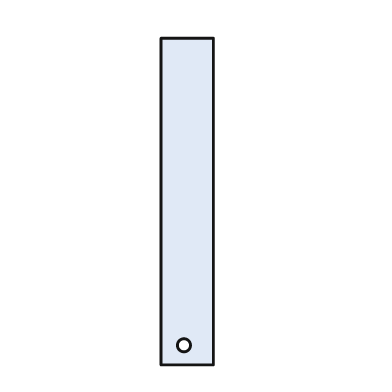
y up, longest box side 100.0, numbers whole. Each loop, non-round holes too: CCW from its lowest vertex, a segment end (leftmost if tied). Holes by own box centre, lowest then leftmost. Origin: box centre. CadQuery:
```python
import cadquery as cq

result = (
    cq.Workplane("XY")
    .moveTo(-8.0, -50.0)
    .lineTo(8.0, -50.0)
    .lineTo(8.0, 50.0)
    .lineTo(-8.0, 50.0)
    .close()
    .moveTo(-1.0, -44.0)
    .circle(2.0)
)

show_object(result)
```